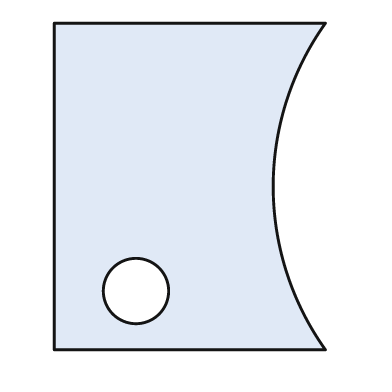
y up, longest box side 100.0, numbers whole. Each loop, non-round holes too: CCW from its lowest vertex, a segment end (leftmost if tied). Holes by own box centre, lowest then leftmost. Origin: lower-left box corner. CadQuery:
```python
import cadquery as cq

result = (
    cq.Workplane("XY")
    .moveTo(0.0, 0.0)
    .lineTo(83.0, 0.0)
    .threePointArc((67.0, 50.0), (83.0, 100.0))
    .lineTo(0.0, 100.0)
    .close()
    .moveTo(25.0, 18.0)
    .circle(10.0)
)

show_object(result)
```